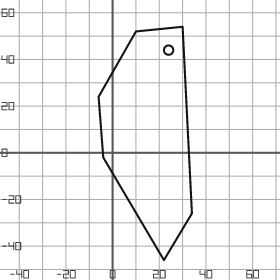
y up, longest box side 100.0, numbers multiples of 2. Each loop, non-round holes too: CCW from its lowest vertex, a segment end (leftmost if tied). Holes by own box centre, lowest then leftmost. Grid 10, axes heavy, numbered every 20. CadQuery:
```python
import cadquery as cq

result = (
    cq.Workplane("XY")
    .moveTo(22.0, -46.0)
    .lineTo(34.0, -26.0)
    .lineTo(30.0, 54.0)
    .lineTo(10.0, 52.0)
    .lineTo(-6.0, 24.0)
    .lineTo(-4.0, -2.0)
    .close()
    .moveTo(24.0, 44.0)
    .circle(2.0)
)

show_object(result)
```